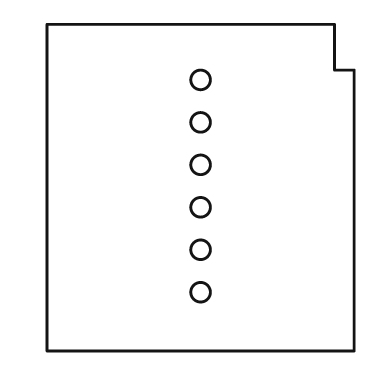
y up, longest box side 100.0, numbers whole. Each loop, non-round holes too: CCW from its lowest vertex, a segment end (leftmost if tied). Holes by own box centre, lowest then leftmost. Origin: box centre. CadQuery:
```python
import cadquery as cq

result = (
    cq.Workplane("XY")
    .moveTo(-47.0, -50.0)
    .lineTo(47.0, -50.0)
    .lineTo(47.0, 36.0)
    .lineTo(41.0, 36.0)
    .lineTo(41.0, 50.0)
    .lineTo(-47.0, 50.0)
    .close()
    .moveTo(0.0, -32.0)
    .circle(3.0)
    .moveTo(0.0, -19.0)
    .circle(3.0)
    .moveTo(0.0, -6.0)
    .circle(3.0)
    .moveTo(0.0, 7.0)
    .circle(3.0)
    .moveTo(0.0, 20.0)
    .circle(3.0)
    .moveTo(0.0, 33.0)
    .circle(3.0)
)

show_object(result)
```